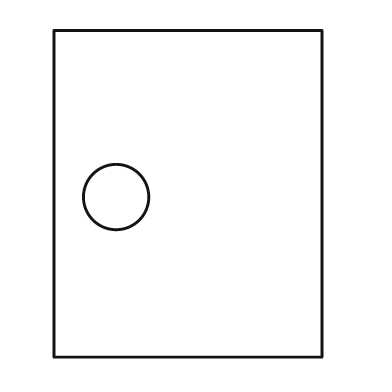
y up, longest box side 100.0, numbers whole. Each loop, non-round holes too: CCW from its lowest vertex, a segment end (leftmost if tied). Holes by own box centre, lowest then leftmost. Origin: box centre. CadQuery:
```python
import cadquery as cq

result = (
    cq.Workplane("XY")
    .moveTo(-41.0, -50.0)
    .lineTo(41.0, -50.0)
    .lineTo(41.0, 50.0)
    .lineTo(-41.0, 50.0)
    .close()
    .moveTo(-22.0, -1.0)
    .circle(10.0)
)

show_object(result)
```